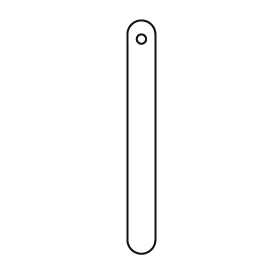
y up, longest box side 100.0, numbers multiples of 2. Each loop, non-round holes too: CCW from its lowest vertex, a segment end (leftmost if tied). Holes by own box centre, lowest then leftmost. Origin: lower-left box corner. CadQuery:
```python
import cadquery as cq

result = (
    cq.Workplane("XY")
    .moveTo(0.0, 6.0)
    .threePointArc((6.0, 0.0), (12.0, 6.0))
    .lineTo(12.0, 94.0)
    .threePointArc((6.0, 100.0), (0.0, 94.0))
    .close()
    .moveTo(6.0, 92.0)
    .circle(2.0)
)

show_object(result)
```